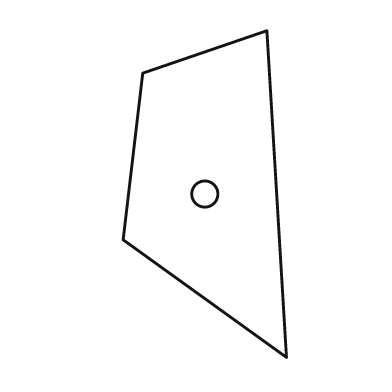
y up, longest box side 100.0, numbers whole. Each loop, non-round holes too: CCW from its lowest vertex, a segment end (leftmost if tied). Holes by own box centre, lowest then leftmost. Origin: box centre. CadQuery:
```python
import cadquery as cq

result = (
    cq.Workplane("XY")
    .moveTo(25.0, -50.0)
    .lineTo(19.0, 50.0)
    .lineTo(-19.0, 37.0)
    .lineTo(-25.0, -14.0)
    .close()
    .moveTo(0.0, 0.0)
    .circle(4.0)
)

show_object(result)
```